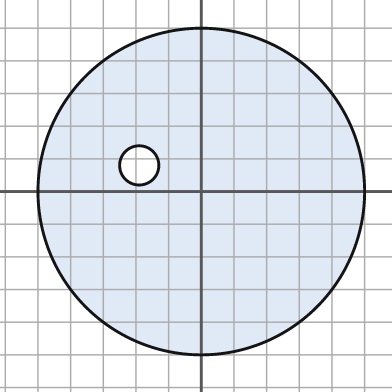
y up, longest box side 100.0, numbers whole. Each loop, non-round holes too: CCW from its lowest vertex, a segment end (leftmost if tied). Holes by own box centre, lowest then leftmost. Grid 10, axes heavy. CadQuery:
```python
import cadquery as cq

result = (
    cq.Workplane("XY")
    .moveTo(0.0, 0.0)
    .circle(50.0)
    .moveTo(-19.0, 8.0)
    .circle(6.0)
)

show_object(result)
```